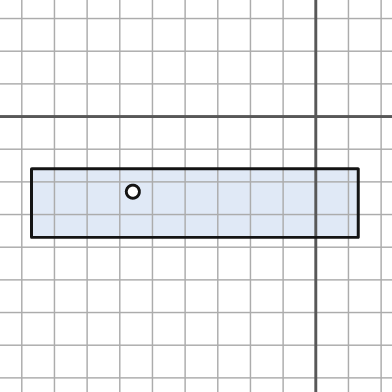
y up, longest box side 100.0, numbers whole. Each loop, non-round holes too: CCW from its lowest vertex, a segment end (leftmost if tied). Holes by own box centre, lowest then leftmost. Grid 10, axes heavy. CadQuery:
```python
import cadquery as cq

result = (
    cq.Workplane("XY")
    .moveTo(-87.0, -37.0)
    .lineTo(13.0, -37.0)
    .lineTo(13.0, -16.0)
    .lineTo(-87.0, -16.0)
    .close()
    .moveTo(-56.0, -23.0)
    .circle(2.0)
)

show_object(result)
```